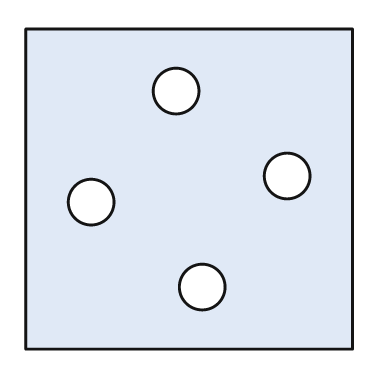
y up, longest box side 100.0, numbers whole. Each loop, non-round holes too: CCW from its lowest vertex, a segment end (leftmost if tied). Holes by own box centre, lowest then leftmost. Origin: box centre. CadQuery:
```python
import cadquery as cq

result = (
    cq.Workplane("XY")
    .moveTo(-50.0, -49.0)
    .lineTo(50.0, -49.0)
    .lineTo(50.0, 49.0)
    .lineTo(-50.0, 49.0)
    .close()
    .moveTo(4.0, -30.0)
    .circle(7.0)
    .moveTo(-30.0, -4.0)
    .circle(7.0)
    .moveTo(30.0, 4.0)
    .circle(7.0)
    .moveTo(-4.0, 30.0)
    .circle(7.0)
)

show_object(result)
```